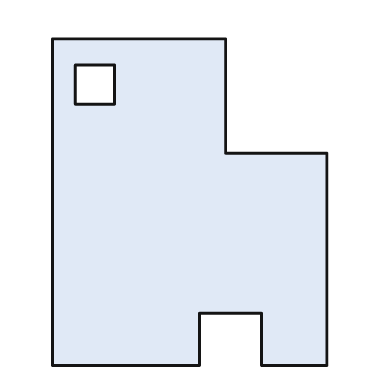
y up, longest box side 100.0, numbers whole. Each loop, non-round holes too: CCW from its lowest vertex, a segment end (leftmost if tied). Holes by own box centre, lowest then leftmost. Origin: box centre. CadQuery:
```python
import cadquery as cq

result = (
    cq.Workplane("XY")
    .moveTo(-42.0, -50.0)
    .lineTo(3.0, -50.0)
    .lineTo(3.0, -34.0)
    .lineTo(22.0, -34.0)
    .lineTo(22.0, -50.0)
    .lineTo(42.0, -50.0)
    .lineTo(42.0, 15.0)
    .lineTo(11.0, 15.0)
    .lineTo(11.0, 50.0)
    .lineTo(-42.0, 50.0)
    .close()
    .moveTo(-35.0, 30.0)
    .lineTo(-23.0, 30.0)
    .lineTo(-23.0, 42.0)
    .lineTo(-35.0, 42.0)
    .close()
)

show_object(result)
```